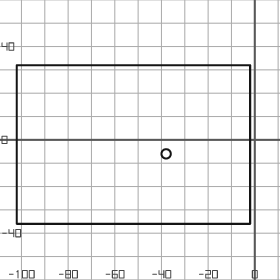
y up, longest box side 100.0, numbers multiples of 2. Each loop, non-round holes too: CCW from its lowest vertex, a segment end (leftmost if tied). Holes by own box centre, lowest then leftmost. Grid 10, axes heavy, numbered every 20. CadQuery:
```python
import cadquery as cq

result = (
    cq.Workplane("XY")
    .moveTo(-102.0, -36.0)
    .lineTo(-2.0, -36.0)
    .lineTo(-2.0, 32.0)
    .lineTo(-102.0, 32.0)
    .close()
    .moveTo(-38.0, -6.0)
    .circle(2.0)
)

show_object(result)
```